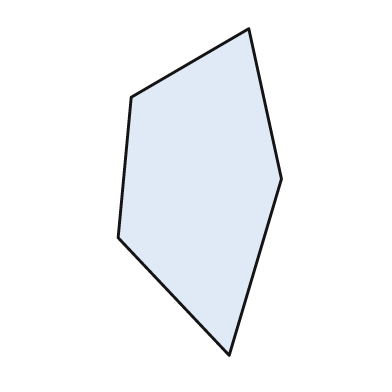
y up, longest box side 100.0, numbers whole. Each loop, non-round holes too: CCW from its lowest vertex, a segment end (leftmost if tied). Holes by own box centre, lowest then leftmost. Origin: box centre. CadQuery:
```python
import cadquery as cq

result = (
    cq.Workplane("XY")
    .moveTo(9.0, -50.0)
    .lineTo(25.0, 4.0)
    .lineTo(15.0, 50.0)
    .lineTo(-21.0, 29.0)
    .lineTo(-25.0, -14.0)
    .close()
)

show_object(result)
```